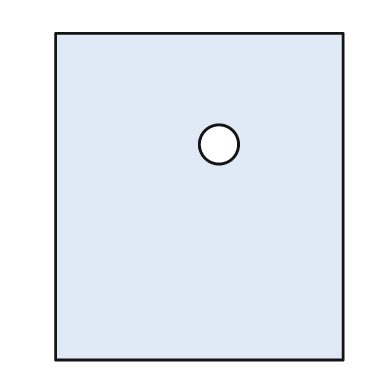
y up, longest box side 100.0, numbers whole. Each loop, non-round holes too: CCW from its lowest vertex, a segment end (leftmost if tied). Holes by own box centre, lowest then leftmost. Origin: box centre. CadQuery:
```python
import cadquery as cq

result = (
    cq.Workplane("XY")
    .moveTo(-44.0, -50.0)
    .lineTo(44.0, -50.0)
    .lineTo(44.0, 50.0)
    .lineTo(-44.0, 50.0)
    .close()
    .moveTo(6.0, 16.0)
    .circle(6.0)
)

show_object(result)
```